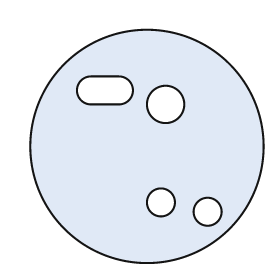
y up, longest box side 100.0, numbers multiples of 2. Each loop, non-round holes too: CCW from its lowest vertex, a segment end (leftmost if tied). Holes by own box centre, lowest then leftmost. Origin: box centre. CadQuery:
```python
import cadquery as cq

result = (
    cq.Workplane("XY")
    .moveTo(0.0, 0.0)
    .circle(50.0)
    .moveTo(26.0, -28.0)
    .circle(6.0)
    .moveTo(6.0, -24.0)
    .circle(6.0)
    .moveTo(8.0, 18.0)
    .circle(8.0)
    .moveTo(-24.0, 18.0)
    .lineTo(-12.0, 18.0)
    .threePointArc((-6.0, 24.0), (-12.0, 30.0))
    .lineTo(-24.0, 30.0)
    .threePointArc((-30.0, 24.0), (-24.0, 18.0))
    .close()
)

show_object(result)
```